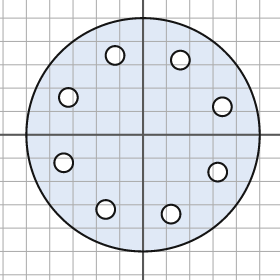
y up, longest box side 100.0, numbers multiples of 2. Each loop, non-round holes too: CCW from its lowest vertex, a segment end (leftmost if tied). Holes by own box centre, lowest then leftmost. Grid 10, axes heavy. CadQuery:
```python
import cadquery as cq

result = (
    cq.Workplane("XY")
    .moveTo(0.0, 0.0)
    .circle(50.0)
    .moveTo(12.0, -34.0)
    .circle(4.0)
    .moveTo(-16.0, -32.0)
    .circle(4.0)
    .moveTo(32.0, -16.0)
    .circle(4.0)
    .moveTo(-34.0, -12.0)
    .circle(4.0)
    .moveTo(34.0, 12.0)
    .circle(4.0)
    .moveTo(-32.0, 16.0)
    .circle(4.0)
    .moveTo(16.0, 32.0)
    .circle(4.0)
    .moveTo(-12.0, 34.0)
    .circle(4.0)
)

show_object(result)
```